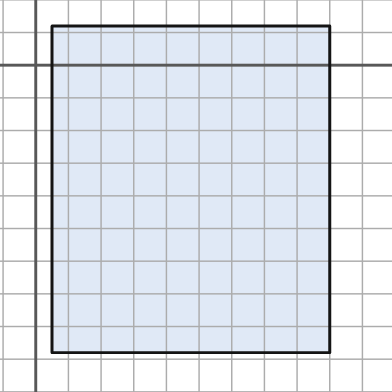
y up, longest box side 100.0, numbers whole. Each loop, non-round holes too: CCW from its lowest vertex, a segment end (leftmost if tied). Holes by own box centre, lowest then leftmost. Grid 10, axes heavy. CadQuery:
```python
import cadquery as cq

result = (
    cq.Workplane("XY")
    .moveTo(5.0, -88.0)
    .lineTo(90.0, -88.0)
    .lineTo(90.0, 12.0)
    .lineTo(5.0, 12.0)
    .close()
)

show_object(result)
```